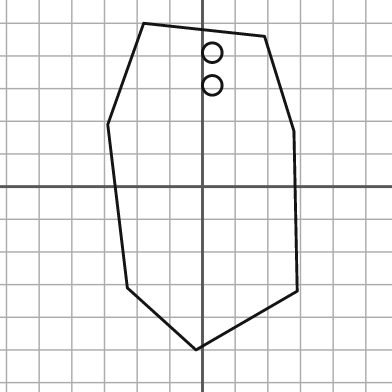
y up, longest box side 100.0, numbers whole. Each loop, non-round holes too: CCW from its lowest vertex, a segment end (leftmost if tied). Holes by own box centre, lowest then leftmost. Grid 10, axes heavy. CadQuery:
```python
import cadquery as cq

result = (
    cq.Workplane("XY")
    .moveTo(-2.0, -50.0)
    .lineTo(29.0, -32.0)
    .lineTo(28.0, 17.0)
    .lineTo(19.0, 46.0)
    .lineTo(-18.0, 50.0)
    .lineTo(-29.0, 19.0)
    .lineTo(-23.0, -31.0)
    .close()
    .moveTo(3.0, 31.0)
    .circle(3.0)
    .moveTo(3.0, 41.0)
    .circle(3.0)
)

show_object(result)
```